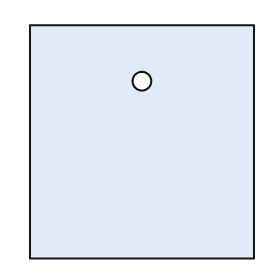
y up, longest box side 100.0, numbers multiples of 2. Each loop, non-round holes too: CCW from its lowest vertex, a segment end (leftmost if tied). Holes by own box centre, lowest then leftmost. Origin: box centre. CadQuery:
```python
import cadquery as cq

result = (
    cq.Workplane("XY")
    .moveTo(-48.0, -50.0)
    .lineTo(48.0, -50.0)
    .lineTo(48.0, 50.0)
    .lineTo(-48.0, 50.0)
    .close()
    .moveTo(0.0, 26.0)
    .circle(4.0)
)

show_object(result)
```